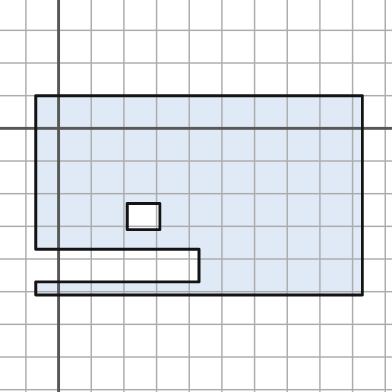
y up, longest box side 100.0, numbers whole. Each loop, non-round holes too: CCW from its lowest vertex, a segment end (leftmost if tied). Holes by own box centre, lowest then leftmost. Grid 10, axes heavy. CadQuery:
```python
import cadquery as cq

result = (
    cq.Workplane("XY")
    .moveTo(-7.0, -51.0)
    .lineTo(93.0, -51.0)
    .lineTo(93.0, 10.0)
    .lineTo(-7.0, 10.0)
    .lineTo(-7.0, -37.0)
    .lineTo(43.0, -37.0)
    .lineTo(43.0, -47.0)
    .lineTo(-7.0, -47.0)
    .close()
    .moveTo(21.0, -31.0)
    .lineTo(31.0, -31.0)
    .lineTo(31.0, -23.0)
    .lineTo(21.0, -23.0)
    .close()
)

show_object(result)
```